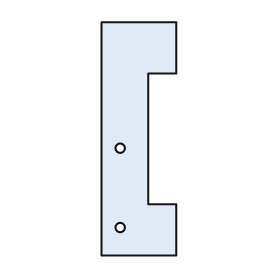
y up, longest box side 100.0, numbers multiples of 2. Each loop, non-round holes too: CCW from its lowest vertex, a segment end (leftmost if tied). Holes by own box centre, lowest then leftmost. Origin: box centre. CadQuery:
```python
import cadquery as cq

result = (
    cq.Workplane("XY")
    .moveTo(-16.0, -50.0)
    .lineTo(16.0, -50.0)
    .lineTo(16.0, -28.0)
    .lineTo(4.0, -28.0)
    .lineTo(4.0, 28.0)
    .lineTo(16.0, 28.0)
    .lineTo(16.0, 50.0)
    .lineTo(-16.0, 50.0)
    .close()
    .moveTo(-8.0, -38.0)
    .circle(2.0)
    .moveTo(-8.0, -4.0)
    .circle(2.0)
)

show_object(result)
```